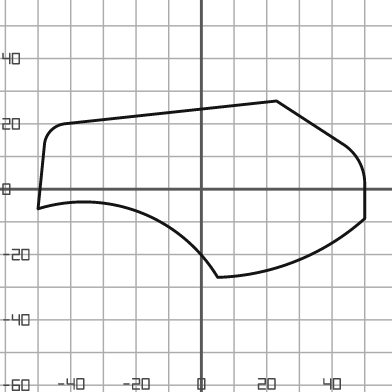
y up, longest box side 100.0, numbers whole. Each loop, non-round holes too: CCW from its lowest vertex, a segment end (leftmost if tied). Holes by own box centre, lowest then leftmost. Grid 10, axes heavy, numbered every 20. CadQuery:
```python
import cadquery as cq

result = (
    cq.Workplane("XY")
    .moveTo(5.0, -27.0)
    .threePointArc((29.0, -22.0), (50.0, -9.0))
    .lineTo(50.0, 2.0)
    .threePointArc((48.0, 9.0), (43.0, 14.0))
    .lineTo(23.0, 27.0)
    .lineTo(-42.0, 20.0)
    .threePointArc((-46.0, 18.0), (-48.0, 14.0))
    .lineTo(-50.0, -6.0)
    .threePointArc((-19.0, -7.0), (5.0, -27.0))
    .close()
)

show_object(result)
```